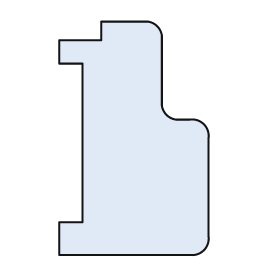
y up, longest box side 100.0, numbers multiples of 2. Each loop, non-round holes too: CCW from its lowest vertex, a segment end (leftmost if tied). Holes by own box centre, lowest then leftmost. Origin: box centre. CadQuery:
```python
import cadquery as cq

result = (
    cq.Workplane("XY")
    .moveTo(-32.0, -50.0)
    .lineTo(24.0, -50.0)
    .threePointArc((30.0, -48.0), (32.0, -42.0))
    .lineTo(32.0, 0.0)
    .threePointArc((30.0, 6.0), (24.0, 8.0))
    .lineTo(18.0, 8.0)
    .threePointArc((14.0, 10.0), (12.0, 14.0))
    .lineTo(12.0, 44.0)
    .threePointArc((10.0, 48.0), (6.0, 50.0))
    .lineTo(-14.0, 50.0)
    .lineTo(-14.0, 42.0)
    .lineTo(-32.0, 42.0)
    .lineTo(-32.0, 32.0)
    .lineTo(-22.0, 32.0)
    .lineTo(-22.0, -36.0)
    .lineTo(-32.0, -36.0)
    .close()
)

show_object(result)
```